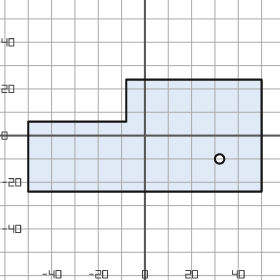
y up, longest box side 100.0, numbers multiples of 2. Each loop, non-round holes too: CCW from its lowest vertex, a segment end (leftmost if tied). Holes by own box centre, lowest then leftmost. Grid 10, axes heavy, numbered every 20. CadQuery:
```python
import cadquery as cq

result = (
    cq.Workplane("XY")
    .moveTo(-50.0, -24.0)
    .lineTo(50.0, -24.0)
    .lineTo(50.0, 24.0)
    .lineTo(-8.0, 24.0)
    .lineTo(-8.0, 6.0)
    .lineTo(-50.0, 6.0)
    .close()
    .moveTo(32.0, -10.0)
    .circle(2.0)
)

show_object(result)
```